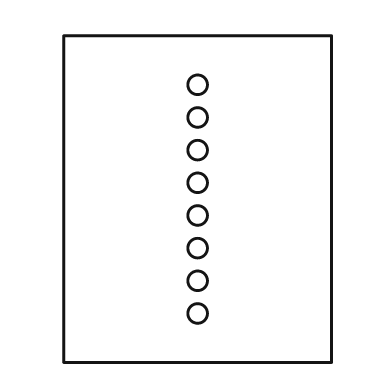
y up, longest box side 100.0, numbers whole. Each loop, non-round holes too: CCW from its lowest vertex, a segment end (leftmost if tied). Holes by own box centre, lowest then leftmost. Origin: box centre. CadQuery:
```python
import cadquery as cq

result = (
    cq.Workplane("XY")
    .moveTo(-41.0, -50.0)
    .lineTo(41.0, -50.0)
    .lineTo(41.0, 50.0)
    .lineTo(-41.0, 50.0)
    .close()
    .moveTo(0.0, -35.0)
    .circle(3.0)
    .moveTo(0.0, -25.0)
    .circle(3.0)
    .moveTo(0.0, -15.0)
    .circle(3.0)
    .moveTo(0.0, -5.0)
    .circle(3.0)
    .moveTo(0.0, 5.0)
    .circle(3.0)
    .moveTo(0.0, 15.0)
    .circle(3.0)
    .moveTo(0.0, 25.0)
    .circle(3.0)
    .moveTo(0.0, 35.0)
    .circle(3.0)
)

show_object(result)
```